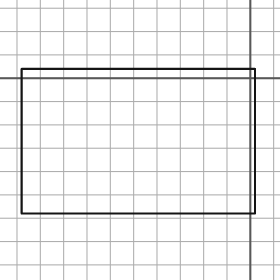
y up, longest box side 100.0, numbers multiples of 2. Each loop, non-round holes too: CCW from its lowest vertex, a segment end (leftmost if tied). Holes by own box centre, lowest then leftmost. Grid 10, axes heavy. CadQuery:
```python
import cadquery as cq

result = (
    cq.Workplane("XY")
    .moveTo(-98.0, -58.0)
    .lineTo(2.0, -58.0)
    .lineTo(2.0, 4.0)
    .lineTo(-98.0, 4.0)
    .close()
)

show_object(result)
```